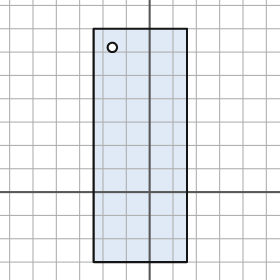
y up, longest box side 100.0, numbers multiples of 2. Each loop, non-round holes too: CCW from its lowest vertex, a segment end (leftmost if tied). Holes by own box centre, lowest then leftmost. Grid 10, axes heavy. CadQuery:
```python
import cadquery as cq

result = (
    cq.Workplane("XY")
    .moveTo(-24.0, -30.0)
    .lineTo(16.0, -30.0)
    .lineTo(16.0, 70.0)
    .lineTo(-24.0, 70.0)
    .close()
    .moveTo(-16.0, 62.0)
    .circle(2.0)
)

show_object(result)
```